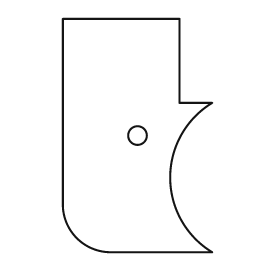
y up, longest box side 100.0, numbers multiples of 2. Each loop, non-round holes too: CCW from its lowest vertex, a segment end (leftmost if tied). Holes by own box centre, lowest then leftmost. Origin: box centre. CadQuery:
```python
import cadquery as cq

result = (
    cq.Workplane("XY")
    .moveTo(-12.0, -50.0)
    .lineTo(32.0, -50.0)
    .threePointArc((14.0, -18.0), (32.0, 14.0))
    .lineTo(18.0, 14.0)
    .lineTo(18.0, 50.0)
    .lineTo(-32.0, 50.0)
    .lineTo(-32.0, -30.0)
    .threePointArc((-26.0, -44.0), (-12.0, -50.0))
    .close()
    .moveTo(0.0, 0.0)
    .circle(4.0)
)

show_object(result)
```